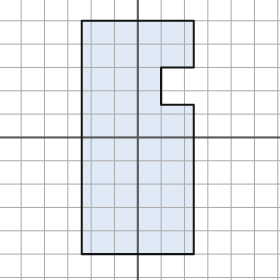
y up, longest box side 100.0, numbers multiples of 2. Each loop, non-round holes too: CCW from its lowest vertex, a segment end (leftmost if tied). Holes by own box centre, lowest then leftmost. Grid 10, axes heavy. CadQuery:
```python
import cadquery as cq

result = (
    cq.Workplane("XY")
    .moveTo(-24.0, -50.0)
    .lineTo(24.0, -50.0)
    .lineTo(24.0, 14.0)
    .lineTo(10.0, 14.0)
    .lineTo(10.0, 30.0)
    .lineTo(24.0, 30.0)
    .lineTo(24.0, 50.0)
    .lineTo(-24.0, 50.0)
    .close()
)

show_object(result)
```